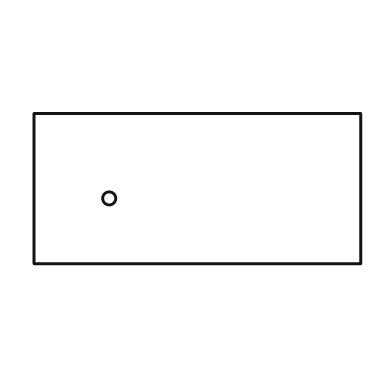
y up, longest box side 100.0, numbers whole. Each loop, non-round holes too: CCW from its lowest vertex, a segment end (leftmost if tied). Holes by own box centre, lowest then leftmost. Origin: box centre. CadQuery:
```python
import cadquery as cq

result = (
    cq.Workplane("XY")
    .moveTo(-50.0, -23.0)
    .lineTo(50.0, -23.0)
    .lineTo(50.0, 23.0)
    .lineTo(-50.0, 23.0)
    .close()
    .moveTo(-27.0, -3.0)
    .circle(2.0)
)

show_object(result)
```